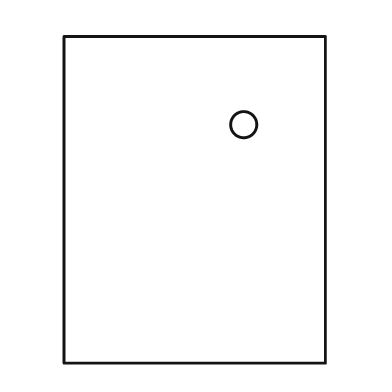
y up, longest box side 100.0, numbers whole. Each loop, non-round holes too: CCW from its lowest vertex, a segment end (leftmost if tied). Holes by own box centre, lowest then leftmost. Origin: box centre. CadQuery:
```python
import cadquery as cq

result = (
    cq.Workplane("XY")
    .moveTo(-40.0, -50.0)
    .lineTo(40.0, -50.0)
    .lineTo(40.0, 50.0)
    .lineTo(-40.0, 50.0)
    .close()
    .moveTo(15.0, 23.0)
    .circle(4.0)
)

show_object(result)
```